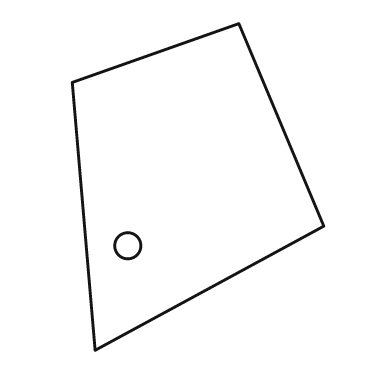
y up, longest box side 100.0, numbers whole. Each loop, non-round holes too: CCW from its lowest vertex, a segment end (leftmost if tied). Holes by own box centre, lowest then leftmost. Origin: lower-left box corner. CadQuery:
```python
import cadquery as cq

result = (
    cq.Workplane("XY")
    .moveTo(7.0, 0.0)
    .lineTo(77.0, 38.0)
    .lineTo(51.0, 100.0)
    .lineTo(0.0, 82.0)
    .close()
    .moveTo(17.0, 32.0)
    .circle(4.0)
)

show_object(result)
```